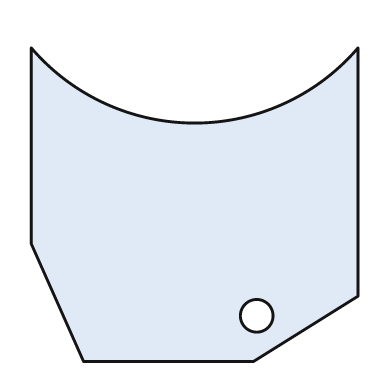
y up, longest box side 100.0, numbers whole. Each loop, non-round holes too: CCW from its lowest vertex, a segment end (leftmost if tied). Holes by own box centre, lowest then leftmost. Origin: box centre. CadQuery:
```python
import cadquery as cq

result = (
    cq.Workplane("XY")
    .moveTo(-34.0, -48.0)
    .lineTo(18.0, -48.0)
    .lineTo(50.0, -28.0)
    .lineTo(50.0, 48.0)
    .threePointArc((0.0, 25.0), (-50.0, 48.0))
    .lineTo(-50.0, -12.0)
    .close()
    .moveTo(19.0, -34.0)
    .circle(5.0)
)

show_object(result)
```